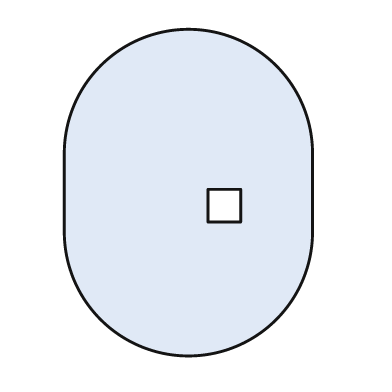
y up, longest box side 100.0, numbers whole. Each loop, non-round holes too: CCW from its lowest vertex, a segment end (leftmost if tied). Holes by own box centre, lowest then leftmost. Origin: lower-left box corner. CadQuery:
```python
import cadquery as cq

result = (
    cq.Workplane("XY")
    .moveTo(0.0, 38.0)
    .threePointArc((38.0, 0.0), (76.0, 38.0))
    .lineTo(76.0, 62.0)
    .threePointArc((38.0, 100.0), (0.0, 62.0))
    .close()
    .moveTo(44.0, 41.0)
    .lineTo(54.0, 41.0)
    .lineTo(54.0, 51.0)
    .lineTo(44.0, 51.0)
    .close()
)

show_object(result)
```